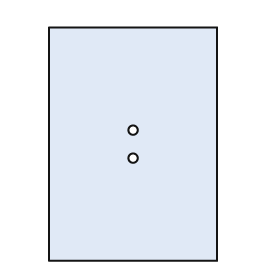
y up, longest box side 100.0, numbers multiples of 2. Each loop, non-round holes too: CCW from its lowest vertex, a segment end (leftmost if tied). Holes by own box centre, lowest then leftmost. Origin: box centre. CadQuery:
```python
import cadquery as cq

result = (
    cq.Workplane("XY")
    .moveTo(-36.0, -50.0)
    .lineTo(36.0, -50.0)
    .lineTo(36.0, 50.0)
    .lineTo(-36.0, 50.0)
    .close()
    .moveTo(0.0, -6.0)
    .circle(2.0)
    .moveTo(0.0, 6.0)
    .circle(2.0)
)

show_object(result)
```